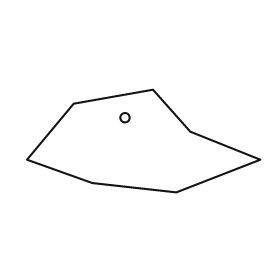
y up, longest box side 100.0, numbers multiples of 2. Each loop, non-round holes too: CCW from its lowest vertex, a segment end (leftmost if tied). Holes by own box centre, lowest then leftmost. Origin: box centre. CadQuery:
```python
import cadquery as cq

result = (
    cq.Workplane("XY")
    .moveTo(14.0, -22.0)
    .lineTo(50.0, -8.0)
    .lineTo(20.0, 4.0)
    .lineTo(4.0, 22.0)
    .lineTo(-30.0, 16.0)
    .lineTo(-50.0, -8.0)
    .lineTo(-22.0, -18.0)
    .close()
    .moveTo(-8.0, 10.0)
    .circle(2.0)
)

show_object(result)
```